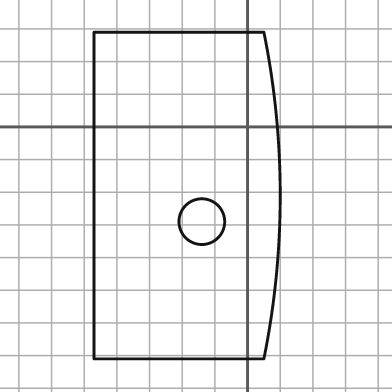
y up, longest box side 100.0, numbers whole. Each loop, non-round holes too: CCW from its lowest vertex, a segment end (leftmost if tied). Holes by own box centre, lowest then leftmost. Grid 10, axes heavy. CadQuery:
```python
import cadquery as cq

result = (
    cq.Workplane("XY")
    .moveTo(-47.0, -71.0)
    .lineTo(5.0, -71.0)
    .threePointArc((10.0, -21.0), (5.0, 29.0))
    .lineTo(-47.0, 29.0)
    .close()
    .moveTo(-14.0, -29.0)
    .circle(7.0)
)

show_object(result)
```